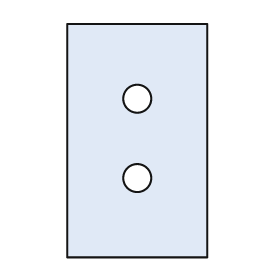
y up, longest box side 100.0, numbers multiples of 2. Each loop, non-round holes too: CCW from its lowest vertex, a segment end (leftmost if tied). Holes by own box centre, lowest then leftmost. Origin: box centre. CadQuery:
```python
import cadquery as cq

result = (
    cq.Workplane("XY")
    .moveTo(-30.0, -50.0)
    .lineTo(30.0, -50.0)
    .lineTo(30.0, 50.0)
    .lineTo(-30.0, 50.0)
    .close()
    .moveTo(0.0, -16.0)
    .circle(6.0)
    .moveTo(0.0, 18.0)
    .circle(6.0)
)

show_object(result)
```